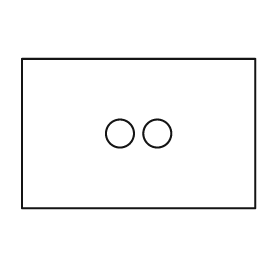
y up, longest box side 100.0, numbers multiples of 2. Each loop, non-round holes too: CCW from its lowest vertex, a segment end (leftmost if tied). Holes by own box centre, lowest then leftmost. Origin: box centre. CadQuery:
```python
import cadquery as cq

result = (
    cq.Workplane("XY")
    .moveTo(-50.0, -32.0)
    .lineTo(50.0, -32.0)
    .lineTo(50.0, 32.0)
    .lineTo(-50.0, 32.0)
    .close()
    .moveTo(-8.0, 0.0)
    .circle(6.0)
    .moveTo(8.0, 0.0)
    .circle(6.0)
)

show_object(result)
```